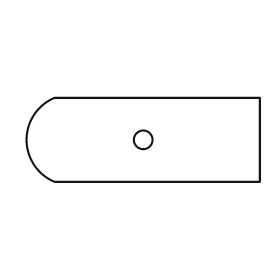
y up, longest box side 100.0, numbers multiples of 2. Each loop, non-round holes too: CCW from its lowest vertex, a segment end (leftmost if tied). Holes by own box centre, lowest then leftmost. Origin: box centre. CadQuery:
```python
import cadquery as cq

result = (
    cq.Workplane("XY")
    .moveTo(-38.0, -18.0)
    .lineTo(50.0, -18.0)
    .lineTo(50.0, 18.0)
    .lineTo(-38.0, 18.0)
    .threePointArc((-50.0, 0.0), (-38.0, -18.0))
    .close()
    .moveTo(0.0, 0.0)
    .circle(4.0)
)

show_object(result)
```